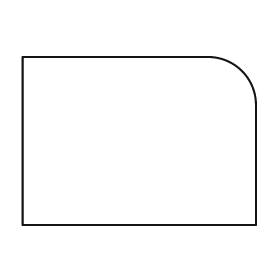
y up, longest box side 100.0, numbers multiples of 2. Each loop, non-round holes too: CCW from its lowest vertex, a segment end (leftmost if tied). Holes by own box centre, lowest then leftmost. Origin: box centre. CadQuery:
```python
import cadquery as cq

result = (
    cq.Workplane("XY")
    .moveTo(-50.0, -36.0)
    .lineTo(50.0, -36.0)
    .lineTo(50.0, 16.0)
    .threePointArc((44.0, 30.0), (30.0, 36.0))
    .lineTo(-50.0, 36.0)
    .close()
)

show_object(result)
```